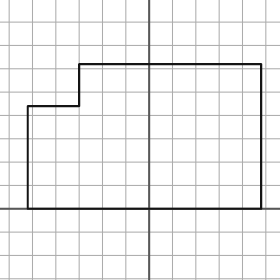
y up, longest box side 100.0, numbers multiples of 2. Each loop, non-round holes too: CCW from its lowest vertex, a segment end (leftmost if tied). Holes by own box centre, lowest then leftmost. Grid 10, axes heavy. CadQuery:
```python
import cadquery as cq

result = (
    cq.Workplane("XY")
    .moveTo(-52.0, 0.0)
    .lineTo(48.0, 0.0)
    .lineTo(48.0, 62.0)
    .lineTo(-30.0, 62.0)
    .lineTo(-30.0, 44.0)
    .lineTo(-52.0, 44.0)
    .close()
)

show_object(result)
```